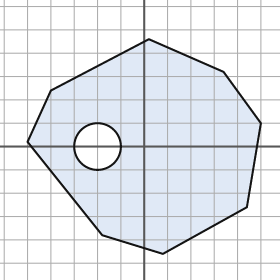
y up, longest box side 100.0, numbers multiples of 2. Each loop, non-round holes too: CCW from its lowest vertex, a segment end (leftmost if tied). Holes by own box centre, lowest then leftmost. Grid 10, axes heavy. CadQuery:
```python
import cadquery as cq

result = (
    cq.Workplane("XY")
    .moveTo(8.0, -46.0)
    .lineTo(44.0, -26.0)
    .lineTo(50.0, 10.0)
    .lineTo(34.0, 32.0)
    .lineTo(2.0, 46.0)
    .lineTo(-40.0, 24.0)
    .lineTo(-50.0, 2.0)
    .lineTo(-18.0, -38.0)
    .close()
    .moveTo(-20.0, 0.0)
    .circle(10.0)
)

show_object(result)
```